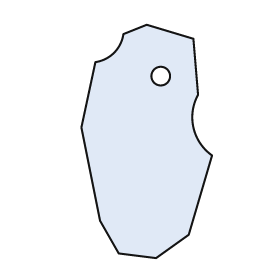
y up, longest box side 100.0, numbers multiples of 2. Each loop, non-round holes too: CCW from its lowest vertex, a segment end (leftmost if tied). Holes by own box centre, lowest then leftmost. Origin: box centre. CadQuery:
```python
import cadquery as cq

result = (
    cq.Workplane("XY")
    .moveTo(4.0, -50.0)
    .lineTo(18.0, -40.0)
    .lineTo(28.0, -6.0)
    .threePointArc((20.0, 6.0), (22.0, 20.0))
    .lineTo(20.0, 44.0)
    .lineTo(0.0, 50.0)
    .lineTo(-10.0, 46.0)
    .threePointArc((-14.0, 38.0), (-22.0, 34.0))
    .lineTo(-28.0, 6.0)
    .lineTo(-20.0, -34.0)
    .lineTo(-12.0, -48.0)
    .close()
    .moveTo(6.0, 28.0)
    .circle(4.0)
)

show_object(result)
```